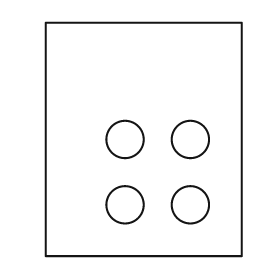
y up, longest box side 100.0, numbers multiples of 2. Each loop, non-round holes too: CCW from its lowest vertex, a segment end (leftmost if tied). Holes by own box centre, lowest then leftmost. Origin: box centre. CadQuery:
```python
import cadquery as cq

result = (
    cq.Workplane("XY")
    .moveTo(-42.0, -50.0)
    .lineTo(42.0, -50.0)
    .lineTo(42.0, 50.0)
    .lineTo(-42.0, 50.0)
    .close()
    .moveTo(-8.0, -28.0)
    .circle(8.0)
    .moveTo(20.0, -28.0)
    .circle(8.0)
    .moveTo(-8.0, 0.0)
    .circle(8.0)
    .moveTo(20.0, 0.0)
    .circle(8.0)
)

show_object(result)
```